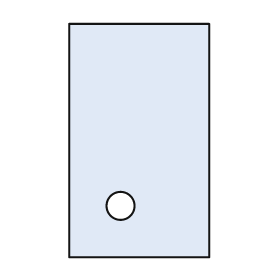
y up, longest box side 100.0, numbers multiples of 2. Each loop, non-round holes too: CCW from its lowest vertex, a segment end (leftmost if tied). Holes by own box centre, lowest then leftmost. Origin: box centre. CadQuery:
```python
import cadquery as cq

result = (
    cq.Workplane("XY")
    .moveTo(-30.0, -50.0)
    .lineTo(30.0, -50.0)
    .lineTo(30.0, 50.0)
    .lineTo(-30.0, 50.0)
    .close()
    .moveTo(-8.0, -28.0)
    .circle(6.0)
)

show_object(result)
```